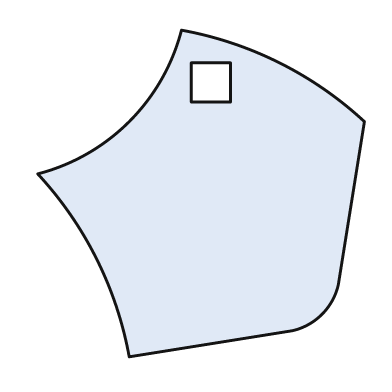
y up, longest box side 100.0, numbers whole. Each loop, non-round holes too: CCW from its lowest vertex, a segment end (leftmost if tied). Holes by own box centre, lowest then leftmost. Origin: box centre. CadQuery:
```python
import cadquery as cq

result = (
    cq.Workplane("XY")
    .moveTo(-22.0, -50.0)
    .lineTo(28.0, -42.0)
    .threePointArc((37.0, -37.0), (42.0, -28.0))
    .lineTo(50.0, 22.0)
    .threePointArc((24.0, 40.0), (-6.0, 50.0))
    .threePointArc((-22.0, 22.0), (-50.0, 6.0))
    .threePointArc((-32.0, -20.0), (-22.0, -50.0))
    .close()
    .moveTo(-3.0, 28.0)
    .lineTo(9.0, 28.0)
    .lineTo(9.0, 40.0)
    .lineTo(-3.0, 40.0)
    .close()
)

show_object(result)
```